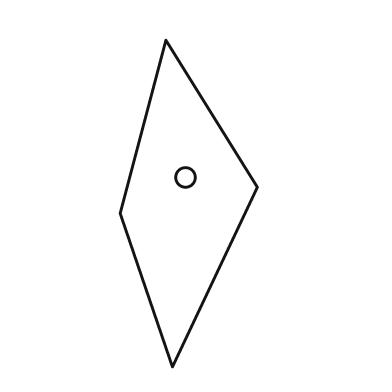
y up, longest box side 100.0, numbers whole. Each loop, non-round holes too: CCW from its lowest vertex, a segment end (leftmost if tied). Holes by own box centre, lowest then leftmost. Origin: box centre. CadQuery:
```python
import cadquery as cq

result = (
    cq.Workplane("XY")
    .moveTo(-5.0, -50.0)
    .lineTo(21.0, 5.0)
    .lineTo(-7.0, 50.0)
    .lineTo(-21.0, -3.0)
    .close()
    .moveTo(-1.0, 8.0)
    .circle(3.0)
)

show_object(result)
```